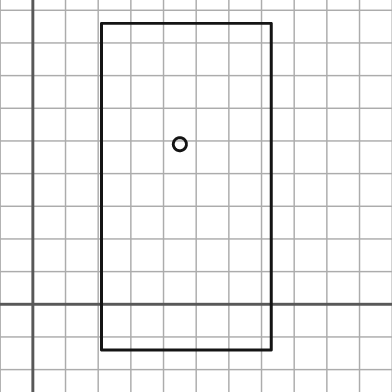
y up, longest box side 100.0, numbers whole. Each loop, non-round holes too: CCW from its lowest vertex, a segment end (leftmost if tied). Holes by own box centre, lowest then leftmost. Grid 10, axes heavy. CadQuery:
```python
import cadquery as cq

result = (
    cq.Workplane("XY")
    .moveTo(21.0, -14.0)
    .lineTo(73.0, -14.0)
    .lineTo(73.0, 86.0)
    .lineTo(21.0, 86.0)
    .close()
    .moveTo(45.0, 49.0)
    .circle(2.0)
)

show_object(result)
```